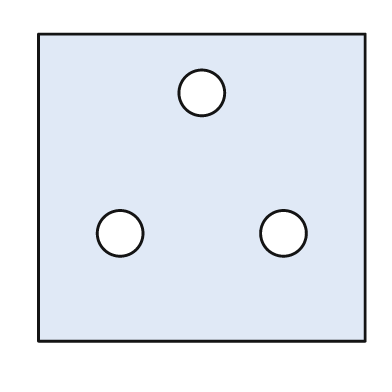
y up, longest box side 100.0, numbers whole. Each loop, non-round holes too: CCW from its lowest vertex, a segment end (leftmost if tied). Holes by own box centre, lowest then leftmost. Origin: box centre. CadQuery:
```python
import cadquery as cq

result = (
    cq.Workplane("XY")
    .moveTo(-50.0, -47.0)
    .lineTo(50.0, -47.0)
    .lineTo(50.0, 47.0)
    .lineTo(-50.0, 47.0)
    .close()
    .moveTo(-25.0, -14.0)
    .circle(7.0)
    .moveTo(25.0, -14.0)
    .circle(7.0)
    .moveTo(0.0, 29.0)
    .circle(7.0)
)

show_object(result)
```